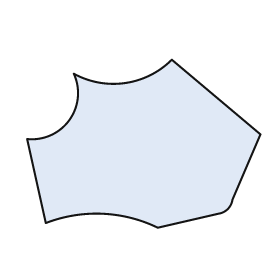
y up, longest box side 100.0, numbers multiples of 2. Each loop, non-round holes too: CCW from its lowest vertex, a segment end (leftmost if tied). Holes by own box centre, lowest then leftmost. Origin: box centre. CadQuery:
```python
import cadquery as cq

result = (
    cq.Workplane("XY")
    .moveTo(6.0, -36.0)
    .lineTo(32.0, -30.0)
    .threePointArc((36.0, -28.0), (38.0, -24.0))
    .lineTo(50.0, 4.0)
    .lineTo(12.0, 36.0)
    .threePointArc((-8.0, 26.0), (-30.0, 30.0))
    .threePointArc((-32.0, 10.0), (-50.0, 2.0))
    .lineTo(-42.0, -34.0)
    .threePointArc((-18.0, -30.0), (6.0, -36.0))
    .close()
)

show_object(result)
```